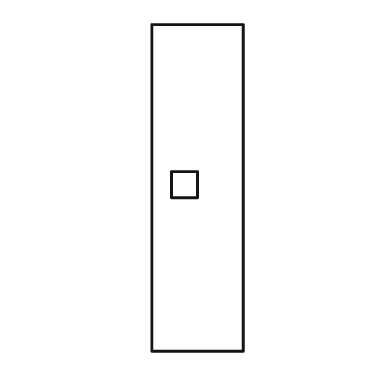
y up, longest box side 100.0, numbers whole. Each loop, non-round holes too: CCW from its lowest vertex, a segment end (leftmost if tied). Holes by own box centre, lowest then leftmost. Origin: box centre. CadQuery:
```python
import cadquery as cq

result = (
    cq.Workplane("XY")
    .moveTo(-14.0, -50.0)
    .lineTo(14.0, -50.0)
    .lineTo(14.0, 50.0)
    .lineTo(-14.0, 50.0)
    .close()
    .moveTo(-8.0, -3.0)
    .lineTo(0.0, -3.0)
    .lineTo(0.0, 5.0)
    .lineTo(-8.0, 5.0)
    .close()
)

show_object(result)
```